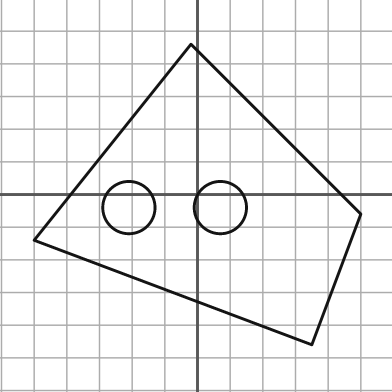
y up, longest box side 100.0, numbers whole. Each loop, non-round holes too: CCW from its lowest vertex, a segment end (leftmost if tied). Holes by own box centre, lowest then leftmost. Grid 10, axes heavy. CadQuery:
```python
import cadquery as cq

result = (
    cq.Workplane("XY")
    .moveTo(35.0, -46.0)
    .lineTo(50.0, -6.0)
    .lineTo(-2.0, 46.0)
    .lineTo(-50.0, -14.0)
    .close()
    .moveTo(-21.0, -4.0)
    .circle(8.0)
    .moveTo(7.0, -4.0)
    .circle(8.0)
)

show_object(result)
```